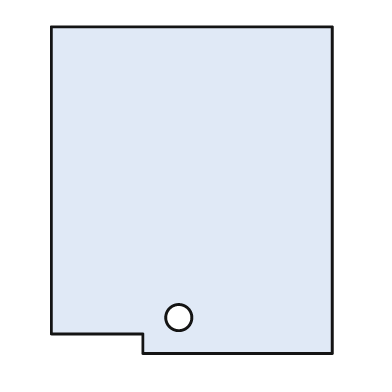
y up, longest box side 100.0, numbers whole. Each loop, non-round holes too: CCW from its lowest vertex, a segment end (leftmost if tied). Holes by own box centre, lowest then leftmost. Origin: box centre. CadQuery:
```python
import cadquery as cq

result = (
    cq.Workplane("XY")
    .moveTo(-15.0, -50.0)
    .lineTo(43.0, -50.0)
    .lineTo(43.0, 50.0)
    .lineTo(-43.0, 50.0)
    .lineTo(-43.0, -44.0)
    .lineTo(-15.0, -44.0)
    .close()
    .moveTo(-4.0, -39.0)
    .circle(4.0)
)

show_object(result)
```